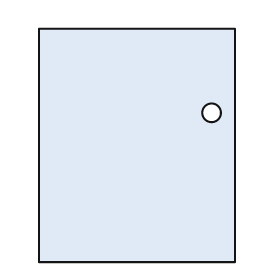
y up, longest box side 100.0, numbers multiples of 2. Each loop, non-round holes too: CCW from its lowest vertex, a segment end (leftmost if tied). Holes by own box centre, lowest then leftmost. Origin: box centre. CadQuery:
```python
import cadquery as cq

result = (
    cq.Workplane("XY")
    .moveTo(-42.0, -50.0)
    .lineTo(42.0, -50.0)
    .lineTo(42.0, 50.0)
    .lineTo(-42.0, 50.0)
    .close()
    .moveTo(32.0, 14.0)
    .circle(4.0)
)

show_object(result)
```